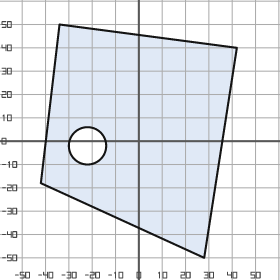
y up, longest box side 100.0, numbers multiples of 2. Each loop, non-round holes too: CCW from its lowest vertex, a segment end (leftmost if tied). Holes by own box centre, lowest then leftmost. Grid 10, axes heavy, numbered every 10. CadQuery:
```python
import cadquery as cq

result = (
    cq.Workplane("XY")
    .moveTo(28.0, -50.0)
    .lineTo(42.0, 40.0)
    .lineTo(-34.0, 50.0)
    .lineTo(-42.0, -18.0)
    .close()
    .moveTo(-22.0, -2.0)
    .circle(8.0)
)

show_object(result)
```